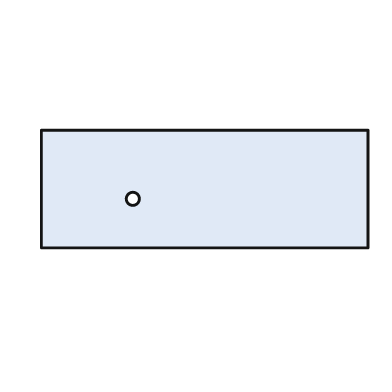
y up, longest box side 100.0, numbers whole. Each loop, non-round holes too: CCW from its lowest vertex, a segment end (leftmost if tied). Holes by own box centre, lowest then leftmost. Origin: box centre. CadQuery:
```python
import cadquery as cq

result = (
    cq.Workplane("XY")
    .moveTo(-50.0, -18.0)
    .lineTo(50.0, -18.0)
    .lineTo(50.0, 18.0)
    .lineTo(-50.0, 18.0)
    .close()
    .moveTo(-22.0, -3.0)
    .circle(2.0)
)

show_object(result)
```